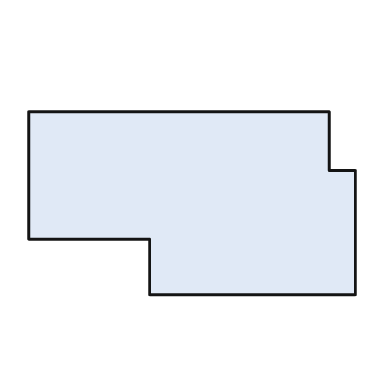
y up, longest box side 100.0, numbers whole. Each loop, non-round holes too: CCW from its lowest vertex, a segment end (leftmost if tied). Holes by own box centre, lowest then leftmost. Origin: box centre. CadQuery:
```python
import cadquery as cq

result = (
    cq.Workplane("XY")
    .moveTo(-13.0, -28.0)
    .lineTo(50.0, -28.0)
    .lineTo(50.0, 10.0)
    .lineTo(42.0, 10.0)
    .lineTo(42.0, 28.0)
    .lineTo(-50.0, 28.0)
    .lineTo(-50.0, -11.0)
    .lineTo(-13.0, -11.0)
    .close()
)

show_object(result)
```